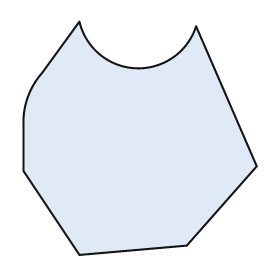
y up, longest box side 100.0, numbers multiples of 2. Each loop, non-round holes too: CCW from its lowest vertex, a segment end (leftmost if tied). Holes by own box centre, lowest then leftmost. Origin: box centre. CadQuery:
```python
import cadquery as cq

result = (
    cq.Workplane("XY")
    .moveTo(-26.0, -50.0)
    .lineTo(20.0, -46.0)
    .lineTo(50.0, -12.0)
    .lineTo(24.0, 48.0)
    .threePointArc((-2.0, 30.0), (-26.0, 50.0))
    .lineTo(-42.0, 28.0)
    .threePointArc((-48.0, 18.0), (-50.0, 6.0))
    .lineTo(-50.0, -14.0)
    .close()
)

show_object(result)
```